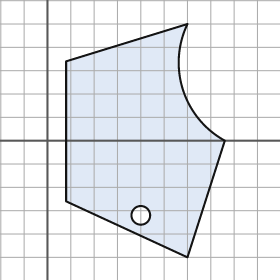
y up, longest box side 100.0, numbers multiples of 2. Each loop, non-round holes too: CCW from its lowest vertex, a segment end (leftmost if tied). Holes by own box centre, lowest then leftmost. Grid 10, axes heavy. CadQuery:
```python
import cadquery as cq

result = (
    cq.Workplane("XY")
    .moveTo(60.0, -50.0)
    .lineTo(76.0, 0.0)
    .threePointArc((58.0, 22.0), (60.0, 50.0))
    .lineTo(8.0, 34.0)
    .lineTo(8.0, -26.0)
    .close()
    .moveTo(40.0, -32.0)
    .circle(4.0)
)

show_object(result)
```